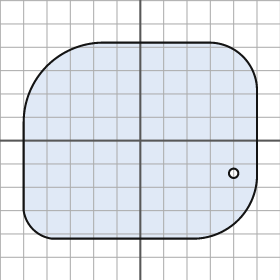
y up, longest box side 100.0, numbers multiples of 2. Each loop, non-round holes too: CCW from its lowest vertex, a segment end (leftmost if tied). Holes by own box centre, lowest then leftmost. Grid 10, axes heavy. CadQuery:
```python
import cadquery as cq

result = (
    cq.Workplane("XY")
    .moveTo(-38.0, -42.0)
    .lineTo(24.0, -42.0)
    .threePointArc((42.0, -34.0), (50.0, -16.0))
    .lineTo(50.0, 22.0)
    .threePointArc((44.0, 36.0), (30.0, 42.0))
    .lineTo(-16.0, 42.0)
    .threePointArc((-40.0, 32.0), (-50.0, 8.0))
    .lineTo(-50.0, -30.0)
    .threePointArc((-46.0, -38.0), (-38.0, -42.0))
    .close()
    .moveTo(40.0, -14.0)
    .circle(2.0)
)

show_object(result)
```